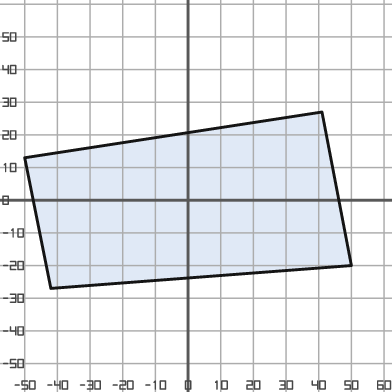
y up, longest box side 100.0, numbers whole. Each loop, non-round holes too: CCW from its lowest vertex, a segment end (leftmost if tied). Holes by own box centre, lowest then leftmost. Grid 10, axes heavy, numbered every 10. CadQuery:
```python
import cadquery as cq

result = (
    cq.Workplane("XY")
    .moveTo(-42.0, -27.0)
    .lineTo(50.0, -20.0)
    .lineTo(41.0, 27.0)
    .lineTo(-50.0, 13.0)
    .close()
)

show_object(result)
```